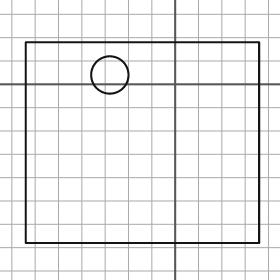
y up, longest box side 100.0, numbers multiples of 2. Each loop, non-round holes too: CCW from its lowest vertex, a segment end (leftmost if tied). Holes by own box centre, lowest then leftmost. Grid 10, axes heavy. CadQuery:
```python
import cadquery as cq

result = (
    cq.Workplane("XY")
    .moveTo(-64.0, -68.0)
    .lineTo(36.0, -68.0)
    .lineTo(36.0, 18.0)
    .lineTo(-64.0, 18.0)
    .close()
    .moveTo(-28.0, 4.0)
    .circle(8.0)
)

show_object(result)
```